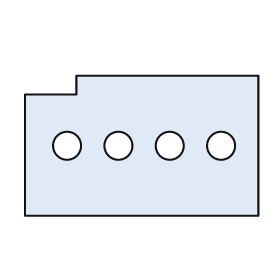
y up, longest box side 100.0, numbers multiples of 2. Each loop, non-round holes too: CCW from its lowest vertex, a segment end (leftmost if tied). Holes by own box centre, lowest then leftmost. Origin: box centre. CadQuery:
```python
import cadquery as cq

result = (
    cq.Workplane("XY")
    .moveTo(-50.0, -30.0)
    .lineTo(50.0, -30.0)
    .lineTo(50.0, 30.0)
    .lineTo(-28.0, 30.0)
    .lineTo(-28.0, 22.0)
    .lineTo(-50.0, 22.0)
    .close()
    .moveTo(-32.0, 0.0)
    .circle(6.0)
    .moveTo(-10.0, 0.0)
    .circle(6.0)
    .moveTo(12.0, 0.0)
    .circle(6.0)
    .moveTo(34.0, 0.0)
    .circle(6.0)
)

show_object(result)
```